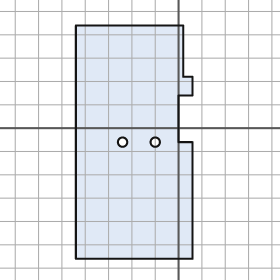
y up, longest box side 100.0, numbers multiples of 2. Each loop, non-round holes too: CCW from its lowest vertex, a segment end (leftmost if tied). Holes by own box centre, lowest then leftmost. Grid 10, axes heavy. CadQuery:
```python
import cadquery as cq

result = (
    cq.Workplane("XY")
    .moveTo(-44.0, -56.0)
    .lineTo(6.0, -56.0)
    .lineTo(6.0, -6.0)
    .lineTo(0.0, -6.0)
    .lineTo(0.0, 14.0)
    .lineTo(6.0, 14.0)
    .lineTo(6.0, 22.0)
    .lineTo(2.0, 22.0)
    .lineTo(2.0, 44.0)
    .lineTo(-44.0, 44.0)
    .close()
    .moveTo(-24.0, -6.0)
    .circle(2.0)
    .moveTo(-10.0, -6.0)
    .circle(2.0)
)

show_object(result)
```